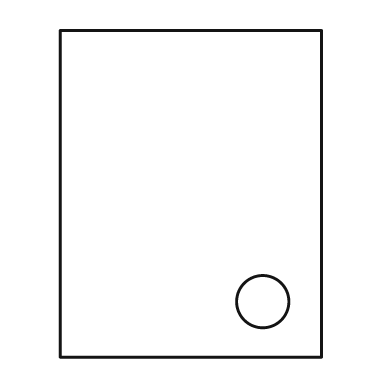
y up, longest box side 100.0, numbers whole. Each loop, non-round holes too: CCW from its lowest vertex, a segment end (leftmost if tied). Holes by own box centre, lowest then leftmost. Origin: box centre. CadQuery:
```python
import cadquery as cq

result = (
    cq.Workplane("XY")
    .moveTo(-40.0, -50.0)
    .lineTo(40.0, -50.0)
    .lineTo(40.0, 50.0)
    .lineTo(-40.0, 50.0)
    .close()
    .moveTo(22.0, -33.0)
    .circle(8.0)
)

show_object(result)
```